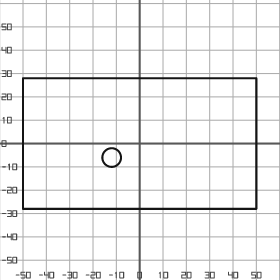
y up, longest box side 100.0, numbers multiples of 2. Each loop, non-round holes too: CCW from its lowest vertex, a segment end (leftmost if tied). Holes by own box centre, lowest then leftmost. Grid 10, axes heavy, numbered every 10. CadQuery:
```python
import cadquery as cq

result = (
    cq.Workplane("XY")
    .moveTo(-50.0, -28.0)
    .lineTo(50.0, -28.0)
    .lineTo(50.0, 28.0)
    .lineTo(-50.0, 28.0)
    .close()
    .moveTo(-12.0, -6.0)
    .circle(4.0)
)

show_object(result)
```